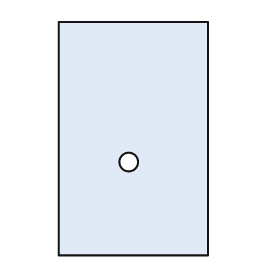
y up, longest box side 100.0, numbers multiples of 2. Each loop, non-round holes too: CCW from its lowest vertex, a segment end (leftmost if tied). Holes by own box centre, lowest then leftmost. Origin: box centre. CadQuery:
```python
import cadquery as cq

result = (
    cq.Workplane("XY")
    .moveTo(-32.0, -50.0)
    .lineTo(32.0, -50.0)
    .lineTo(32.0, 50.0)
    .lineTo(-32.0, 50.0)
    .close()
    .moveTo(-2.0, -10.0)
    .circle(4.0)
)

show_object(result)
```